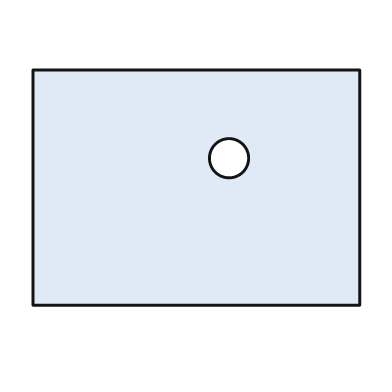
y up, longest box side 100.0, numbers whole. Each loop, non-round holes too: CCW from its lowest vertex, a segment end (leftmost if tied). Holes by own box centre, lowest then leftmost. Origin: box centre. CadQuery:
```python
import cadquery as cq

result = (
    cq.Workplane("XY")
    .moveTo(-50.0, -36.0)
    .lineTo(50.0, -36.0)
    .lineTo(50.0, 36.0)
    .lineTo(-50.0, 36.0)
    .close()
    .moveTo(10.0, 9.0)
    .circle(6.0)
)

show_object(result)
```